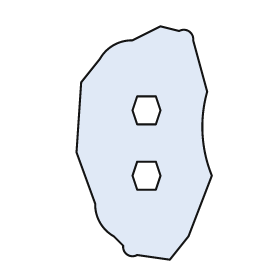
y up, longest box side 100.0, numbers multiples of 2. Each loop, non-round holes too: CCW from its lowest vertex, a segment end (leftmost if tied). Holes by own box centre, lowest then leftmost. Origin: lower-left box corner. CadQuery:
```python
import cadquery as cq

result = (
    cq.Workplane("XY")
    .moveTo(40.0, 0.0)
    .lineTo(48.0, 10.0)
    .lineTo(58.0, 36.0)
    .threePointArc((54.0, 54.0), (56.0, 72.0))
    .lineTo(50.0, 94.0)
    .threePointArc((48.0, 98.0), (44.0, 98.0))
    .lineTo(36.0, 100.0)
    .lineTo(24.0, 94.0)
    .threePointArc((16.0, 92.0), (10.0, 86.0))
    .lineTo(2.0, 76.0)
    .lineTo(0.0, 46.0)
    .lineTo(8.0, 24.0)
    .threePointArc((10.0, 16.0), (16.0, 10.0))
    .lineTo(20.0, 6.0)
    .threePointArc((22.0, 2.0), (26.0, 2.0))
    .close()
    .moveTo(26.0, 30.0)
    .lineTo(34.0, 30.0)
    .lineTo(36.0, 36.0)
    .lineTo(34.0, 42.0)
    .lineTo(26.0, 42.0)
    .lineTo(24.0, 36.0)
    .close()
    .moveTo(26.0, 58.0)
    .lineTo(34.0, 58.0)
    .lineTo(36.0, 64.0)
    .lineTo(34.0, 70.0)
    .lineTo(26.0, 70.0)
    .lineTo(24.0, 64.0)
    .close()
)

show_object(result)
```